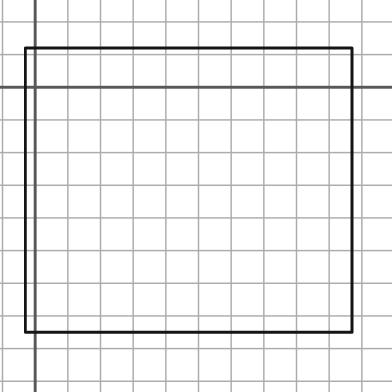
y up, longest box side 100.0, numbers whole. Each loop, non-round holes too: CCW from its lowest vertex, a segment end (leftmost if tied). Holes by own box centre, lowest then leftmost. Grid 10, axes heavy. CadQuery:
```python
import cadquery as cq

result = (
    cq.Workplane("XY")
    .moveTo(-3.0, -75.0)
    .lineTo(97.0, -75.0)
    .lineTo(97.0, 12.0)
    .lineTo(-3.0, 12.0)
    .close()
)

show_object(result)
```